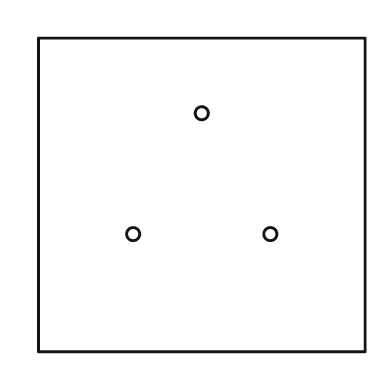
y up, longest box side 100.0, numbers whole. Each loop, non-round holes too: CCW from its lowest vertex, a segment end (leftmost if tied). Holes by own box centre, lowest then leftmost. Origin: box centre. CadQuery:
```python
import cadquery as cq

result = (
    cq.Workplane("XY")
    .moveTo(-50.0, -48.0)
    .lineTo(50.0, -48.0)
    .lineTo(50.0, 48.0)
    .lineTo(-50.0, 48.0)
    .close()
    .moveTo(-21.0, -12.0)
    .circle(2.0)
    .moveTo(21.0, -12.0)
    .circle(2.0)
    .moveTo(0.0, 25.0)
    .circle(2.0)
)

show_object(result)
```